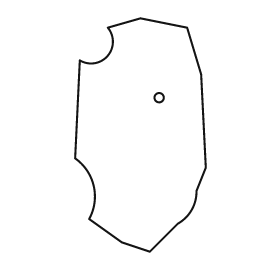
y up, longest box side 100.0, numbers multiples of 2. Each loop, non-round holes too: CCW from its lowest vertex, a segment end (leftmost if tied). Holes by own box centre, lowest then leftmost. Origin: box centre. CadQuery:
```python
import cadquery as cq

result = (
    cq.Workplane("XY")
    .moveTo(4.0, -50.0)
    .lineTo(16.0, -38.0)
    .threePointArc((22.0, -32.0), (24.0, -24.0))
    .lineTo(28.0, -14.0)
    .lineTo(26.0, 26.0)
    .lineTo(20.0, 46.0)
    .lineTo(0.0, 50.0)
    .lineTo(-14.0, 46.0)
    .threePointArc((-14.0, 34.0), (-26.0, 32.0))
    .lineTo(-28.0, -10.0)
    .threePointArc((-20.0, -22.0), (-22.0, -36.0))
    .lineTo(-8.0, -46.0)
    .close()
    .moveTo(8.0, 16.0)
    .circle(2.0)
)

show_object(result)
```